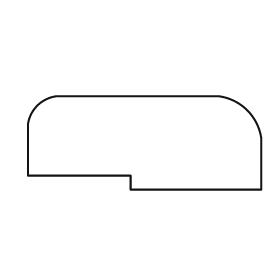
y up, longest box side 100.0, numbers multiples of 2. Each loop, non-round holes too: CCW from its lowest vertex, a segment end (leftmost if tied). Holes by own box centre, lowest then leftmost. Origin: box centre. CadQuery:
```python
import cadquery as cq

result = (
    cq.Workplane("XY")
    .moveTo(-6.0, -20.0)
    .lineTo(50.0, -20.0)
    .lineTo(50.0, 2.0)
    .threePointArc((44.0, 14.0), (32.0, 20.0))
    .lineTo(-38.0, 20.0)
    .threePointArc((-46.0, 16.0), (-50.0, 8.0))
    .lineTo(-50.0, -14.0)
    .lineTo(-6.0, -14.0)
    .close()
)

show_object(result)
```